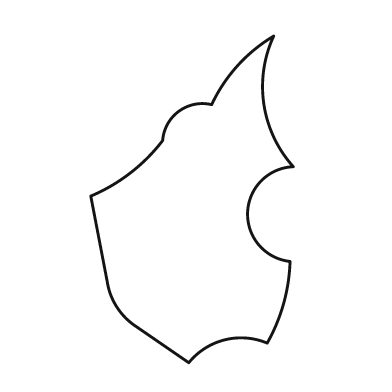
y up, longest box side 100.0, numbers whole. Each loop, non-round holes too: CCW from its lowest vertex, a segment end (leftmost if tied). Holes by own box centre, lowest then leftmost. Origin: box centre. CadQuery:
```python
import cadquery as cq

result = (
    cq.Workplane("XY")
    .moveTo(-1.0, -50.0)
    .threePointArc((10.0, -43.0), (23.0, -44.0))
    .threePointArc((28.0, -32.0), (30.0, -19.0))
    .threePointArc((17.0, -4.0), (31.0, 10.0))
    .threePointArc((22.0, 29.0), (25.0, 50.0))
    .threePointArc((14.0, 41.0), (6.0, 29.0))
    .threePointArc((-4.0, 27.0), (-9.0, 18.0))
    .threePointArc((-19.0, 8.0), (-31.0, 1.0))
    .lineTo(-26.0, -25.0)
    .threePointArc((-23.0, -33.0), (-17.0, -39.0))
    .close()
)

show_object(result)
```